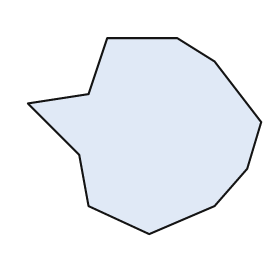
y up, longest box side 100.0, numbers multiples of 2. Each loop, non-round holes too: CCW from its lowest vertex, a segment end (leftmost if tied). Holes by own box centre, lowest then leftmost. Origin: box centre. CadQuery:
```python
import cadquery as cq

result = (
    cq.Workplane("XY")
    .moveTo(2.0, -42.0)
    .lineTo(30.0, -30.0)
    .lineTo(44.0, -14.0)
    .lineTo(50.0, 6.0)
    .lineTo(30.0, 32.0)
    .lineTo(14.0, 42.0)
    .lineTo(-16.0, 42.0)
    .lineTo(-24.0, 18.0)
    .lineTo(-50.0, 14.0)
    .lineTo(-28.0, -8.0)
    .lineTo(-24.0, -30.0)
    .close()
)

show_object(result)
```